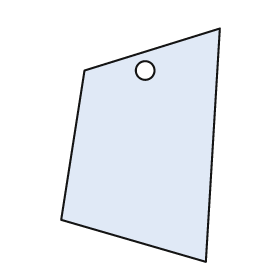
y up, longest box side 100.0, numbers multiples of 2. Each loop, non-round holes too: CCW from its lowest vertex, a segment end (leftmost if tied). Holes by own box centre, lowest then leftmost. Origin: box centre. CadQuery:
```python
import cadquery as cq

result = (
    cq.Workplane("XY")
    .moveTo(28.0, -50.0)
    .lineTo(34.0, 50.0)
    .lineTo(-24.0, 32.0)
    .lineTo(-34.0, -32.0)
    .close()
    .moveTo(2.0, 32.0)
    .circle(4.0)
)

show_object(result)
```